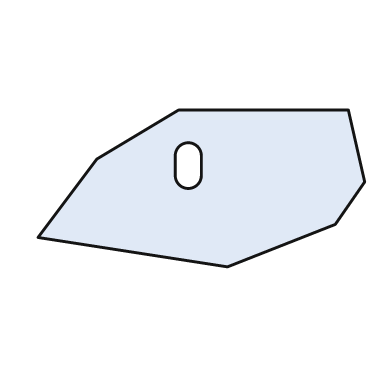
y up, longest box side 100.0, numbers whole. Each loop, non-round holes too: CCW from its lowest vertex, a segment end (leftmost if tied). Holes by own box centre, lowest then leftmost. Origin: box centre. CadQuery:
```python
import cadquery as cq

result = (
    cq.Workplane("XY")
    .moveTo(8.0, -24.0)
    .lineTo(41.0, -11.0)
    .lineTo(50.0, 2.0)
    .lineTo(45.0, 24.0)
    .lineTo(-7.0, 24.0)
    .lineTo(-32.0, 9.0)
    .lineTo(-50.0, -15.0)
    .close()
    .moveTo(-8.0, 4.0)
    .threePointArc((-4.0, 0.0), (0.0, 4.0))
    .lineTo(0.0, 10.0)
    .threePointArc((-4.0, 14.0), (-8.0, 10.0))
    .close()
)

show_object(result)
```